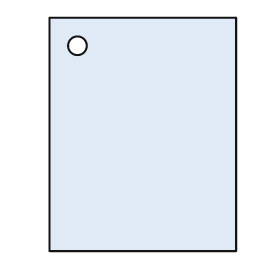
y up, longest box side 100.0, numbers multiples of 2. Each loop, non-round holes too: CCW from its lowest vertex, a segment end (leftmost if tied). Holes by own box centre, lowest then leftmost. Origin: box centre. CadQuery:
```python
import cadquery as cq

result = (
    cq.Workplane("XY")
    .moveTo(-40.0, -50.0)
    .lineTo(40.0, -50.0)
    .lineTo(40.0, 50.0)
    .lineTo(-40.0, 50.0)
    .close()
    .moveTo(-28.0, 38.0)
    .circle(4.0)
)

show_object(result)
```